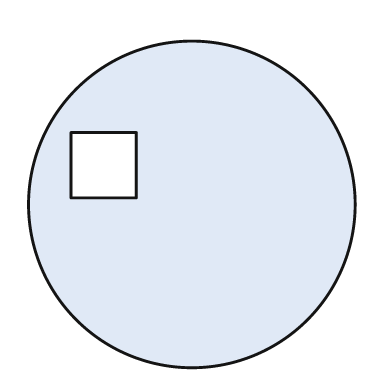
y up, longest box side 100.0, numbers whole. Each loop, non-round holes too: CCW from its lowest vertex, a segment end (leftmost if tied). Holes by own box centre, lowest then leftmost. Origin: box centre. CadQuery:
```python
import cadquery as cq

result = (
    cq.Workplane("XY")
    .moveTo(0.0, 0.0)
    .circle(50.0)
    .moveTo(-37.0, 2.0)
    .lineTo(-17.0, 2.0)
    .lineTo(-17.0, 22.0)
    .lineTo(-37.0, 22.0)
    .close()
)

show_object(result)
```